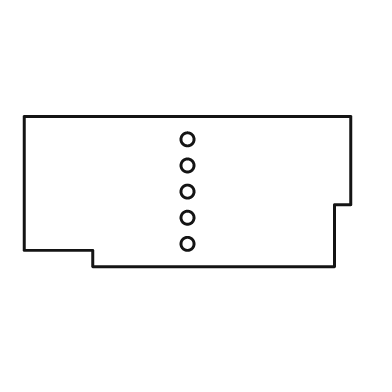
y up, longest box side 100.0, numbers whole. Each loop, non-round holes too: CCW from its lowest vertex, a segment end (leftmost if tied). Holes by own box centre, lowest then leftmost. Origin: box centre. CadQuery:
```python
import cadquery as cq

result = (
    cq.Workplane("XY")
    .moveTo(-29.0, -23.0)
    .lineTo(45.0, -23.0)
    .lineTo(45.0, -4.0)
    .lineTo(50.0, -4.0)
    .lineTo(50.0, 23.0)
    .lineTo(-50.0, 23.0)
    .lineTo(-50.0, -18.0)
    .lineTo(-29.0, -18.0)
    .close()
    .moveTo(0.0, -16.0)
    .circle(2.0)
    .moveTo(0.0, -8.0)
    .circle(2.0)
    .moveTo(0.0, 0.0)
    .circle(2.0)
    .moveTo(0.0, 8.0)
    .circle(2.0)
    .moveTo(0.0, 16.0)
    .circle(2.0)
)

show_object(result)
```